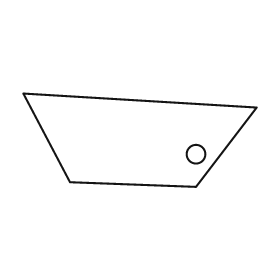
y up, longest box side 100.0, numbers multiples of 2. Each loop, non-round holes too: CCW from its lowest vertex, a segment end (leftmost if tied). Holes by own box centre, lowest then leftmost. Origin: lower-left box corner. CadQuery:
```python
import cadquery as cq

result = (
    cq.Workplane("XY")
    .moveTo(74.0, 0.0)
    .lineTo(100.0, 34.0)
    .lineTo(0.0, 40.0)
    .lineTo(20.0, 2.0)
    .close()
    .moveTo(74.0, 14.0)
    .circle(4.0)
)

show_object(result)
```